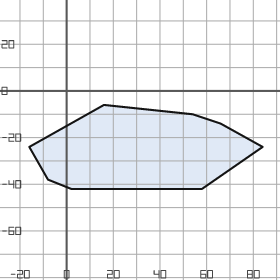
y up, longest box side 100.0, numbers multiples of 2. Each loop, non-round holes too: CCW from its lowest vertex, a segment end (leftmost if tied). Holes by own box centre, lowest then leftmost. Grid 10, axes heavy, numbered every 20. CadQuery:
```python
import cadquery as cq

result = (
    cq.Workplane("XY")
    .moveTo(2.0, -42.0)
    .lineTo(58.0, -42.0)
    .lineTo(84.0, -24.0)
    .lineTo(66.0, -14.0)
    .lineTo(54.0, -10.0)
    .lineTo(16.0, -6.0)
    .lineTo(-16.0, -24.0)
    .lineTo(-8.0, -38.0)
    .close()
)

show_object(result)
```